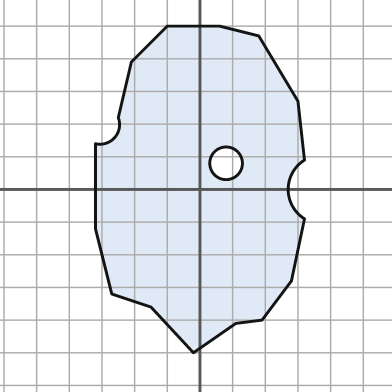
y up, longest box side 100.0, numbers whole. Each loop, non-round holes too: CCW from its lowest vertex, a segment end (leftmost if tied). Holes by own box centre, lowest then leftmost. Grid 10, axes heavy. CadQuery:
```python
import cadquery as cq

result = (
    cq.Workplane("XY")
    .moveTo(-2.0, -50.0)
    .lineTo(11.0, -41.0)
    .lineTo(19.0, -40.0)
    .lineTo(28.0, -28.0)
    .lineTo(32.0, -9.0)
    .threePointArc((27.0, 0.0), (32.0, 9.0))
    .lineTo(30.0, 27.0)
    .lineTo(18.0, 47.0)
    .lineTo(6.0, 50.0)
    .lineTo(-10.0, 50.0)
    .lineTo(-21.0, 39.0)
    .lineTo(-25.0, 22.0)
    .threePointArc((-26.0, 16.0), (-32.0, 14.0))
    .lineTo(-32.0, -12.0)
    .lineTo(-27.0, -32.0)
    .lineTo(-15.0, -36.0)
    .close()
    .moveTo(8.0, 8.0)
    .circle(5.0)
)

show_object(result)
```